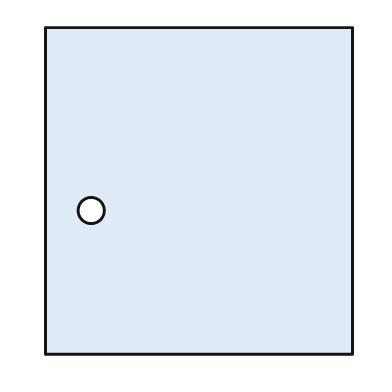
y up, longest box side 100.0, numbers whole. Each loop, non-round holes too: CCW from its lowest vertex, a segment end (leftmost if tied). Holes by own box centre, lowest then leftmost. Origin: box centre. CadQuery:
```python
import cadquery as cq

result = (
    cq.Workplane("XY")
    .moveTo(-47.0, -50.0)
    .lineTo(47.0, -50.0)
    .lineTo(47.0, 50.0)
    .lineTo(-47.0, 50.0)
    .close()
    .moveTo(-33.0, -6.0)
    .circle(4.0)
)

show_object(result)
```